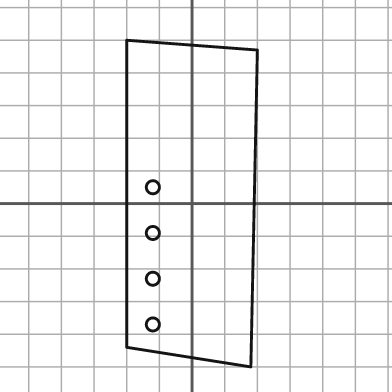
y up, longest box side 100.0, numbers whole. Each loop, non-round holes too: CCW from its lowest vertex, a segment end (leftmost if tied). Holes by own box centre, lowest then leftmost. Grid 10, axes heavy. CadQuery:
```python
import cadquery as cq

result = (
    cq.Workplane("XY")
    .moveTo(18.0, -50.0)
    .lineTo(20.0, 47.0)
    .lineTo(-20.0, 50.0)
    .lineTo(-20.0, -44.0)
    .close()
    .moveTo(-12.0, -37.0)
    .circle(2.0)
    .moveTo(-12.0, -23.0)
    .circle(2.0)
    .moveTo(-12.0, -9.0)
    .circle(2.0)
    .moveTo(-12.0, 5.0)
    .circle(2.0)
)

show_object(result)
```